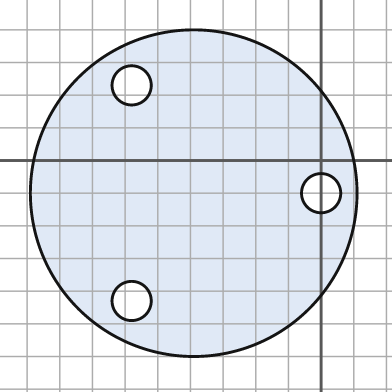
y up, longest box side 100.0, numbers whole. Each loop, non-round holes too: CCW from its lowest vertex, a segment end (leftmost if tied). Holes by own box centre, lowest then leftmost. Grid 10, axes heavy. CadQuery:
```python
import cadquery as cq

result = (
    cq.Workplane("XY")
    .moveTo(-39.0, -10.0)
    .circle(50.0)
    .moveTo(-58.0, -43.0)
    .circle(6.0)
    .moveTo(0.0, -10.0)
    .circle(6.0)
    .moveTo(-58.0, 23.0)
    .circle(6.0)
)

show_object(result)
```